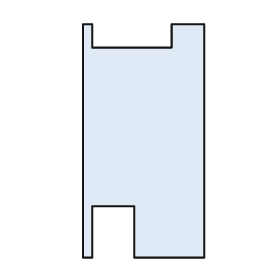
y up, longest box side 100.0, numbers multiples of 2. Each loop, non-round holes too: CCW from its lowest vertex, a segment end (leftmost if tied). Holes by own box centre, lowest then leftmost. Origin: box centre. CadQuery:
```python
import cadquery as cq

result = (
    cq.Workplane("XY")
    .moveTo(-26.0, -50.0)
    .lineTo(-22.0, -50.0)
    .lineTo(-22.0, -28.0)
    .lineTo(-4.0, -28.0)
    .lineTo(-4.0, -50.0)
    .lineTo(26.0, -50.0)
    .lineTo(26.0, 50.0)
    .lineTo(12.0, 50.0)
    .lineTo(12.0, 40.0)
    .lineTo(-22.0, 40.0)
    .lineTo(-22.0, 50.0)
    .lineTo(-26.0, 50.0)
    .close()
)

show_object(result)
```